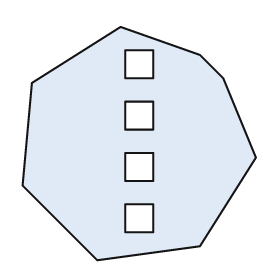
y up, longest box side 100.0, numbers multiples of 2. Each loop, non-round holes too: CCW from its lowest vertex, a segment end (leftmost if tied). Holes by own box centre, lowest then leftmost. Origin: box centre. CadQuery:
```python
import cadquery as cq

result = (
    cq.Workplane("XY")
    .moveTo(-18.0, -50.0)
    .lineTo(26.0, -44.0)
    .lineTo(50.0, -6.0)
    .lineTo(36.0, 28.0)
    .lineTo(26.0, 38.0)
    .lineTo(-8.0, 50.0)
    .lineTo(-46.0, 26.0)
    .lineTo(-50.0, -18.0)
    .close()
    .moveTo(-6.0, -38.0)
    .lineTo(6.0, -38.0)
    .lineTo(6.0, -26.0)
    .lineTo(-6.0, -26.0)
    .close()
    .moveTo(-6.0, -16.0)
    .lineTo(6.0, -16.0)
    .lineTo(6.0, -4.0)
    .lineTo(-6.0, -4.0)
    .close()
    .moveTo(-6.0, 6.0)
    .lineTo(6.0, 6.0)
    .lineTo(6.0, 18.0)
    .lineTo(-6.0, 18.0)
    .close()
    .moveTo(-6.0, 28.0)
    .lineTo(6.0, 28.0)
    .lineTo(6.0, 40.0)
    .lineTo(-6.0, 40.0)
    .close()
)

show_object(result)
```